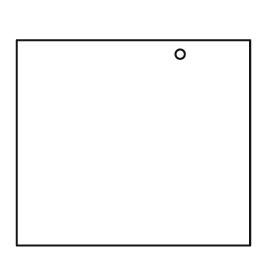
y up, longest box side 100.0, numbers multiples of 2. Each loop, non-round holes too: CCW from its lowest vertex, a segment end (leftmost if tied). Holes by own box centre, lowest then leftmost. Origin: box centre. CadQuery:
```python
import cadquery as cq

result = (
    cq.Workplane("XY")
    .moveTo(-50.0, -44.0)
    .lineTo(50.0, -44.0)
    .lineTo(50.0, 44.0)
    .lineTo(-50.0, 44.0)
    .close()
    .moveTo(20.0, 38.0)
    .circle(2.0)
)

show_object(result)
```